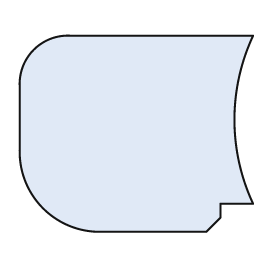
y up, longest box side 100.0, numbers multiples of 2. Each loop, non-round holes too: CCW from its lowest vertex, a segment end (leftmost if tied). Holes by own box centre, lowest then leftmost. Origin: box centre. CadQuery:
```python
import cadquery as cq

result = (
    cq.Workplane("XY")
    .moveTo(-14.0, -42.0)
    .lineTo(30.0, -42.0)
    .lineTo(36.0, -36.0)
    .lineTo(36.0, -30.0)
    .lineTo(50.0, -30.0)
    .threePointArc((42.0, 6.0), (50.0, 42.0))
    .lineTo(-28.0, 42.0)
    .threePointArc((-44.0, 36.0), (-50.0, 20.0))
    .lineTo(-50.0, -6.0)
    .threePointArc((-40.0, -32.0), (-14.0, -42.0))
    .close()
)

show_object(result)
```